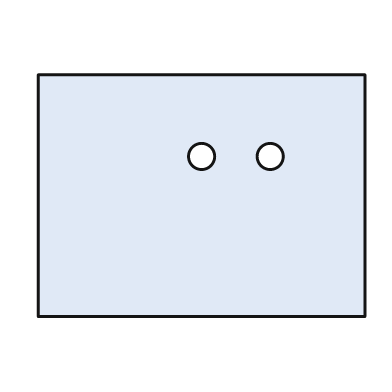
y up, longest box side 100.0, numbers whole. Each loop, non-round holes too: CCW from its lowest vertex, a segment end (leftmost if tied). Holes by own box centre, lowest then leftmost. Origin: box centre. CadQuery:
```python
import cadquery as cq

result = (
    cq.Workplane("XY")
    .moveTo(-50.0, -37.0)
    .lineTo(50.0, -37.0)
    .lineTo(50.0, 37.0)
    .lineTo(-50.0, 37.0)
    .close()
    .moveTo(0.0, 12.0)
    .circle(4.0)
    .moveTo(21.0, 12.0)
    .circle(4.0)
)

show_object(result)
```